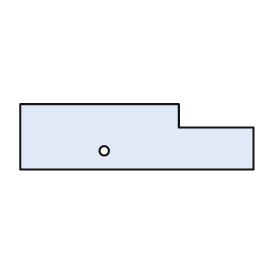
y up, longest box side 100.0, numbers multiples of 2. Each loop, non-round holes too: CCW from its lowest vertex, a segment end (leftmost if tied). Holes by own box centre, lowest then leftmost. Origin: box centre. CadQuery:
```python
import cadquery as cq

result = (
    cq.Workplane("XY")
    .moveTo(-50.0, -14.0)
    .lineTo(50.0, -14.0)
    .lineTo(50.0, 4.0)
    .lineTo(18.0, 4.0)
    .lineTo(18.0, 14.0)
    .lineTo(-50.0, 14.0)
    .close()
    .moveTo(-14.0, -6.0)
    .circle(2.0)
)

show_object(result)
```